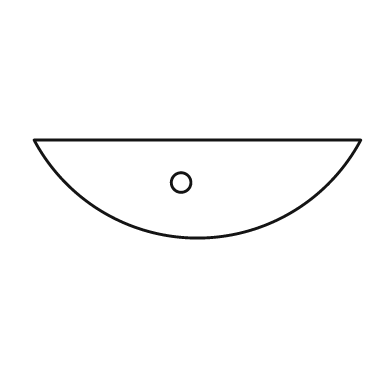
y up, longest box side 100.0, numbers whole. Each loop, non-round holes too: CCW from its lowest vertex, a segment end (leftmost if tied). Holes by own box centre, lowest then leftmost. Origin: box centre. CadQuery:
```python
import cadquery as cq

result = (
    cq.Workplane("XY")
    .moveTo(-50.0, 15.0)
    .threePointArc((0.0, -15.0), (50.0, 15.0))
    .close()
    .moveTo(-5.0, 2.0)
    .circle(3.0)
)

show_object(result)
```